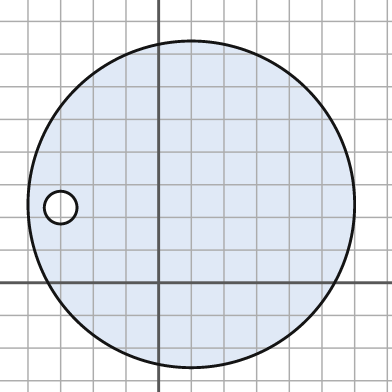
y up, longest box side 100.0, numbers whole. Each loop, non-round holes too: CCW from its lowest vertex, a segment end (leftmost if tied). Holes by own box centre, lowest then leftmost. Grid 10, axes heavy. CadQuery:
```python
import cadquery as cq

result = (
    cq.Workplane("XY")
    .moveTo(10.0, 24.0)
    .circle(50.0)
    .moveTo(-30.0, 23.0)
    .circle(5.0)
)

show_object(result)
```